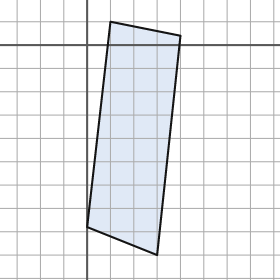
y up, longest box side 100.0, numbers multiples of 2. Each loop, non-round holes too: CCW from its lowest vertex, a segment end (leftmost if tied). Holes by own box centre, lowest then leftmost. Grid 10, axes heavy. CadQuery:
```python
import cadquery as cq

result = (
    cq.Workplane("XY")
    .moveTo(30.0, -90.0)
    .lineTo(40.0, 4.0)
    .lineTo(10.0, 10.0)
    .lineTo(0.0, -78.0)
    .close()
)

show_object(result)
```